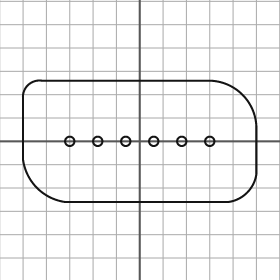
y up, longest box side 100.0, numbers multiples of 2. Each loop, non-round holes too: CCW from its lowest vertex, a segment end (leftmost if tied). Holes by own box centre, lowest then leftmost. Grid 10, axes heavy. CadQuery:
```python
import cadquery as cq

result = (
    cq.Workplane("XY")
    .moveTo(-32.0, -26.0)
    .lineTo(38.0, -26.0)
    .threePointArc((46.0, -22.0), (50.0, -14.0))
    .lineTo(50.0, 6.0)
    .threePointArc((44.0, 20.0), (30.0, 26.0))
    .lineTo(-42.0, 26.0)
    .threePointArc((-48.0, 24.0), (-50.0, 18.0))
    .lineTo(-50.0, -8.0)
    .threePointArc((-44.0, -20.0), (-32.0, -26.0))
    .close()
    .moveTo(-30.0, 0.0)
    .circle(2.0)
    .moveTo(-18.0, 0.0)
    .circle(2.0)
    .moveTo(-6.0, 0.0)
    .circle(2.0)
    .moveTo(6.0, 0.0)
    .circle(2.0)
    .moveTo(18.0, 0.0)
    .circle(2.0)
    .moveTo(30.0, 0.0)
    .circle(2.0)
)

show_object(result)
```